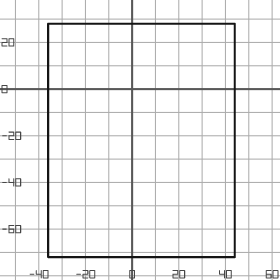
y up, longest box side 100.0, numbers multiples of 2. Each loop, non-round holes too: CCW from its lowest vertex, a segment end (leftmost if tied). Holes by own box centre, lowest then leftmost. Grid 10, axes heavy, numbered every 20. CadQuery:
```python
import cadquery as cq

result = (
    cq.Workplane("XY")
    .moveTo(-36.0, -72.0)
    .lineTo(44.0, -72.0)
    .lineTo(44.0, 28.0)
    .lineTo(-36.0, 28.0)
    .close()
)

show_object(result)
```